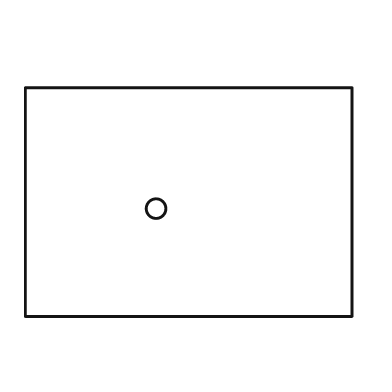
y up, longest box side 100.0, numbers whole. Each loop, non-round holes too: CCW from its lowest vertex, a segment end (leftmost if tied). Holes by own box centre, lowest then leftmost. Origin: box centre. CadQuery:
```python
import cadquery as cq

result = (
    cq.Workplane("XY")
    .moveTo(-50.0, -35.0)
    .lineTo(50.0, -35.0)
    .lineTo(50.0, 35.0)
    .lineTo(-50.0, 35.0)
    .close()
    .moveTo(-10.0, -2.0)
    .circle(3.0)
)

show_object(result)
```